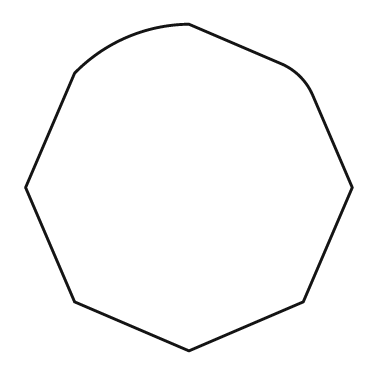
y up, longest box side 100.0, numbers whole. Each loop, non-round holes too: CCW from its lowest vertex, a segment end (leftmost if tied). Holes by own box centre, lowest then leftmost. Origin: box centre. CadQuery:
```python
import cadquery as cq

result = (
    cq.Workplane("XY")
    .moveTo(0.0, -50.0)
    .lineTo(35.0, -35.0)
    .lineTo(50.0, 0.0)
    .lineTo(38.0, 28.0)
    .threePointArc((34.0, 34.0), (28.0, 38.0))
    .lineTo(0.0, 50.0)
    .threePointArc((-19.0, 46.0), (-35.0, 35.0))
    .lineTo(-50.0, 0.0)
    .lineTo(-35.0, -35.0)
    .close()
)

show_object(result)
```